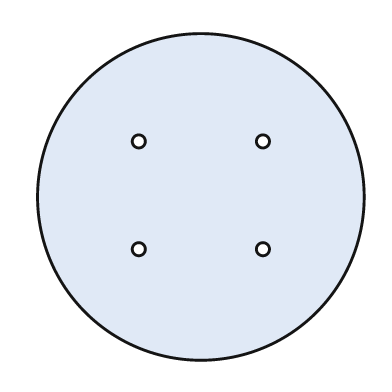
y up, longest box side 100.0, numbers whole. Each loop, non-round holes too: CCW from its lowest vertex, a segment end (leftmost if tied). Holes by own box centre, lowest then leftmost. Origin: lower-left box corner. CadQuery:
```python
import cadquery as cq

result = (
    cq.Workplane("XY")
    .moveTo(50.0, 50.0)
    .circle(50.0)
    .moveTo(31.0, 34.0)
    .circle(2.0)
    .moveTo(69.0, 34.0)
    .circle(2.0)
    .moveTo(31.0, 67.0)
    .circle(2.0)
    .moveTo(69.0, 67.0)
    .circle(2.0)
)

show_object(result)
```